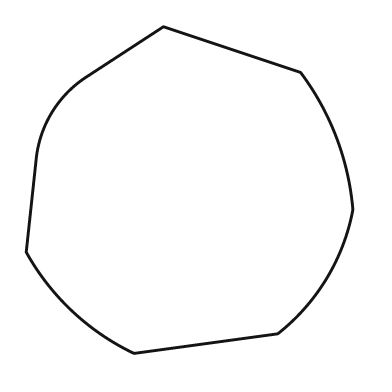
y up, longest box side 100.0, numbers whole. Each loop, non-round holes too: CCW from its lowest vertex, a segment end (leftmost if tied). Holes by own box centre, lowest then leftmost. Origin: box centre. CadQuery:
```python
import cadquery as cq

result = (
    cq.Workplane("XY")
    .moveTo(-17.0, -50.0)
    .lineTo(27.0, -44.0)
    .threePointArc((42.0, -27.0), (50.0, -6.0))
    .threePointArc((45.0, 16.0), (34.0, 36.0))
    .lineTo(-8.0, 50.0)
    .lineTo(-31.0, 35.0)
    .threePointArc((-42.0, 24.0), (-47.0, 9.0))
    .lineTo(-50.0, -19.0)
    .threePointArc((-36.0, -37.0), (-17.0, -50.0))
    .close()
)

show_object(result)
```